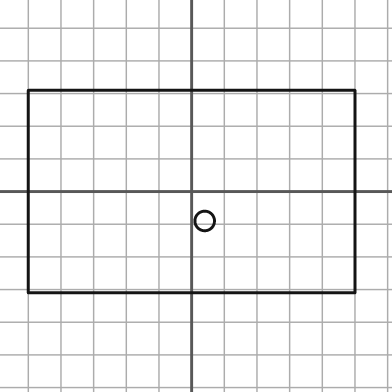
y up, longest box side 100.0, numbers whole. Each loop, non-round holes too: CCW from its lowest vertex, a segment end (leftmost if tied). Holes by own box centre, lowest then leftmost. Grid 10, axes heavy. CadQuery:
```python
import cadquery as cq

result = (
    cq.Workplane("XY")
    .moveTo(-50.0, -31.0)
    .lineTo(50.0, -31.0)
    .lineTo(50.0, 31.0)
    .lineTo(-50.0, 31.0)
    .close()
    .moveTo(4.0, -9.0)
    .circle(3.0)
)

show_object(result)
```